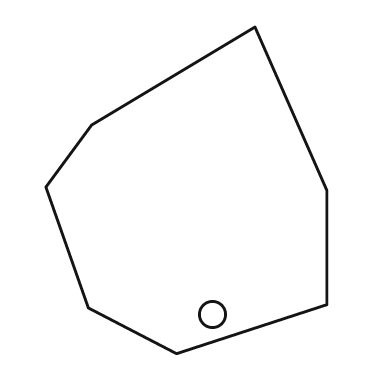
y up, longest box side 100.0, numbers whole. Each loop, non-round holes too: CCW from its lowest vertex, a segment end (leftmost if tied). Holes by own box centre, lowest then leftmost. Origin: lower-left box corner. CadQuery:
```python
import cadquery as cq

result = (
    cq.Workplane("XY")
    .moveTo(40.0, 0.0)
    .lineTo(86.0, 15.0)
    .lineTo(86.0, 50.0)
    .lineTo(64.0, 100.0)
    .lineTo(14.0, 70.0)
    .lineTo(0.0, 51.0)
    .lineTo(13.0, 14.0)
    .close()
    .moveTo(51.0, 12.0)
    .circle(4.0)
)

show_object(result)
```